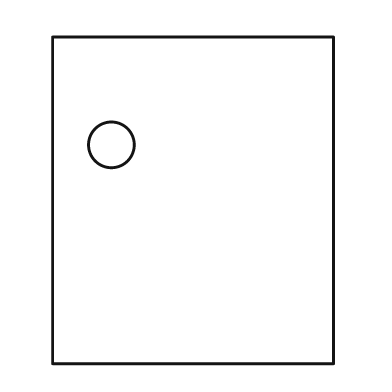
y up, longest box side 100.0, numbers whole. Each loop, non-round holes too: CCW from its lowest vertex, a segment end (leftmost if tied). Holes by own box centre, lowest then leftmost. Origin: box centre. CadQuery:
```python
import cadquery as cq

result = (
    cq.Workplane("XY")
    .moveTo(-43.0, -50.0)
    .lineTo(43.0, -50.0)
    .lineTo(43.0, 50.0)
    .lineTo(-43.0, 50.0)
    .close()
    .moveTo(-25.0, 17.0)
    .circle(7.0)
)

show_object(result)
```